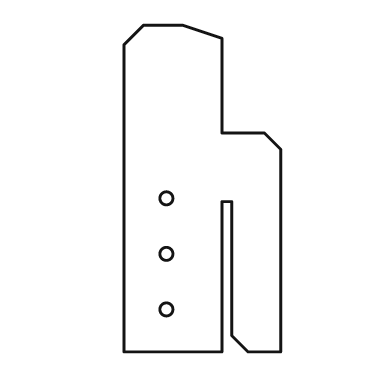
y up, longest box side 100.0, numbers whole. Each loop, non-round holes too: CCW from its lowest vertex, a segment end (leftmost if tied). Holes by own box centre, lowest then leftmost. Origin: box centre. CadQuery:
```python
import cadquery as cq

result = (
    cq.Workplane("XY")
    .moveTo(-24.0, -50.0)
    .lineTo(6.0, -50.0)
    .lineTo(6.0, -4.0)
    .lineTo(9.0, -4.0)
    .lineTo(9.0, -45.0)
    .lineTo(14.0, -50.0)
    .lineTo(24.0, -50.0)
    .lineTo(24.0, 12.0)
    .lineTo(19.0, 17.0)
    .lineTo(6.0, 17.0)
    .lineTo(6.0, 46.0)
    .lineTo(-6.0, 50.0)
    .lineTo(-18.0, 50.0)
    .lineTo(-24.0, 44.0)
    .close()
    .moveTo(-11.0, -37.0)
    .circle(2.0)
    .moveTo(-11.0, -20.0)
    .circle(2.0)
    .moveTo(-11.0, -3.0)
    .circle(2.0)
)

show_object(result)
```